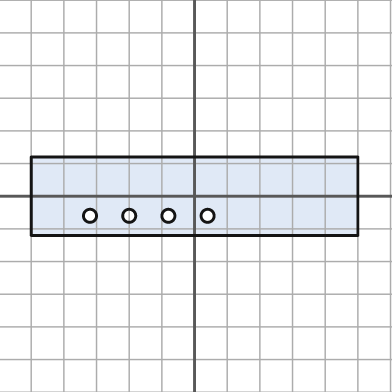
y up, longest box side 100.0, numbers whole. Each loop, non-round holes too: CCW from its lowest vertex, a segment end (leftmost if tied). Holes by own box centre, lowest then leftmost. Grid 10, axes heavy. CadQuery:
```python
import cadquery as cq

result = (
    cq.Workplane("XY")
    .moveTo(-50.0, -12.0)
    .lineTo(50.0, -12.0)
    .lineTo(50.0, 12.0)
    .lineTo(-50.0, 12.0)
    .close()
    .moveTo(-32.0, -6.0)
    .circle(2.0)
    .moveTo(-20.0, -6.0)
    .circle(2.0)
    .moveTo(-8.0, -6.0)
    .circle(2.0)
    .moveTo(4.0, -6.0)
    .circle(2.0)
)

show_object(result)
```